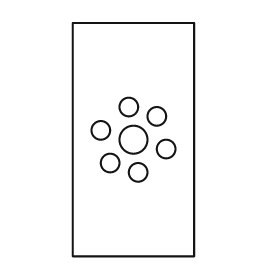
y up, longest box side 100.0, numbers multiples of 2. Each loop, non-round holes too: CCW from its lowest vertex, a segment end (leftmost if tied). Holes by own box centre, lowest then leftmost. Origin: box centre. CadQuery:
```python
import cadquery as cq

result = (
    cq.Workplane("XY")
    .moveTo(-26.0, -50.0)
    .lineTo(26.0, -50.0)
    .lineTo(26.0, 50.0)
    .lineTo(-26.0, 50.0)
    .close()
    .moveTo(2.0, -14.0)
    .circle(4.0)
    .moveTo(-10.0, -10.0)
    .circle(4.0)
    .moveTo(14.0, -4.0)
    .circle(4.0)
    .moveTo(0.0, 0.0)
    .circle(6.0)
    .moveTo(-14.0, 4.0)
    .circle(4.0)
    .moveTo(10.0, 10.0)
    .circle(4.0)
    .moveTo(-2.0, 14.0)
    .circle(4.0)
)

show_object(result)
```